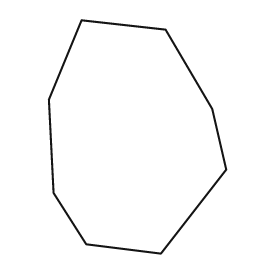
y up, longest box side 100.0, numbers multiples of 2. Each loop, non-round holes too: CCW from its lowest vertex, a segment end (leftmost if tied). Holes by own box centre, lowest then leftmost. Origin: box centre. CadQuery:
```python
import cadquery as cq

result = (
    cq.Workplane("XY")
    .moveTo(10.0, -50.0)
    .lineTo(38.0, -14.0)
    .lineTo(32.0, 12.0)
    .lineTo(12.0, 46.0)
    .lineTo(-24.0, 50.0)
    .lineTo(-38.0, 16.0)
    .lineTo(-36.0, -24.0)
    .lineTo(-22.0, -46.0)
    .close()
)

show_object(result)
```